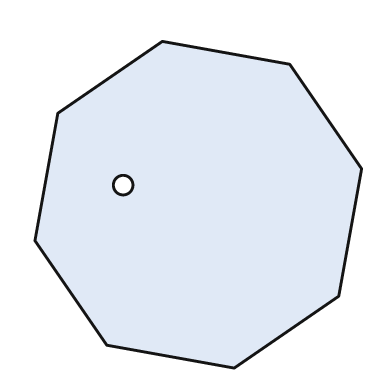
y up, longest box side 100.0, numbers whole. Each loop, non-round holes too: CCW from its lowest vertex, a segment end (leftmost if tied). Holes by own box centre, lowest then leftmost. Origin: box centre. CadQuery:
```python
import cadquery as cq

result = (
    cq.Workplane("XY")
    .moveTo(11.0, -50.0)
    .lineTo(43.0, -28.0)
    .lineTo(50.0, 11.0)
    .lineTo(28.0, 43.0)
    .lineTo(-11.0, 50.0)
    .lineTo(-43.0, 28.0)
    .lineTo(-50.0, -11.0)
    .lineTo(-28.0, -43.0)
    .close()
    .moveTo(-23.0, 6.0)
    .circle(3.0)
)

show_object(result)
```